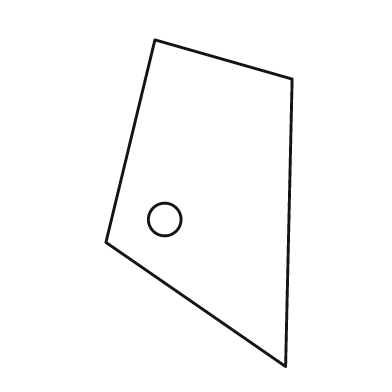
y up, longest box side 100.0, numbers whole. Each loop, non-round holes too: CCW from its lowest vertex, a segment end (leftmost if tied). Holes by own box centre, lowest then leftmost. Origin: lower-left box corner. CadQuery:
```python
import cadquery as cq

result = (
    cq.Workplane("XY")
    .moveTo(55.0, 0.0)
    .lineTo(57.0, 88.0)
    .lineTo(15.0, 100.0)
    .lineTo(0.0, 38.0)
    .close()
    .moveTo(18.0, 45.0)
    .circle(5.0)
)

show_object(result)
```